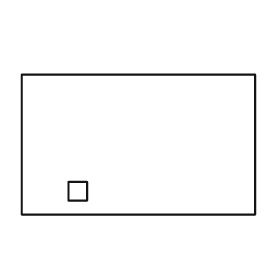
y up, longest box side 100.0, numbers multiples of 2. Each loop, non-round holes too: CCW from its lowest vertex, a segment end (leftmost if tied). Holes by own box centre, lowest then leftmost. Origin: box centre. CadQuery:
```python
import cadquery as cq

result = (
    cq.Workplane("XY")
    .moveTo(-50.0, -30.0)
    .lineTo(50.0, -30.0)
    .lineTo(50.0, 30.0)
    .lineTo(-50.0, 30.0)
    .close()
    .moveTo(-30.0, -24.0)
    .lineTo(-22.0, -24.0)
    .lineTo(-22.0, -16.0)
    .lineTo(-30.0, -16.0)
    .close()
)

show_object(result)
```